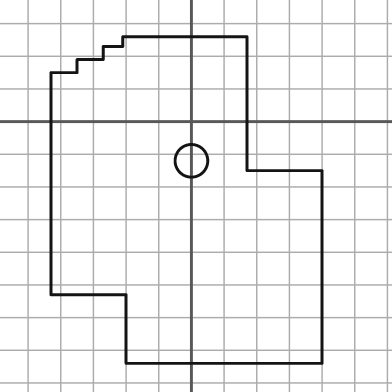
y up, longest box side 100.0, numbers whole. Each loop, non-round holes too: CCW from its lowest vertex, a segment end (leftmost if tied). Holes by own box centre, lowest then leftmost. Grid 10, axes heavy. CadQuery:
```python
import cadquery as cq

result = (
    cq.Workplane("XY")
    .moveTo(-20.0, -74.0)
    .lineTo(40.0, -74.0)
    .lineTo(40.0, -15.0)
    .lineTo(17.0, -15.0)
    .lineTo(17.0, 26.0)
    .lineTo(-21.0, 26.0)
    .lineTo(-21.0, 23.0)
    .lineTo(-27.0, 23.0)
    .lineTo(-27.0, 19.0)
    .lineTo(-35.0, 19.0)
    .lineTo(-35.0, 15.0)
    .lineTo(-43.0, 15.0)
    .lineTo(-43.0, -53.0)
    .lineTo(-20.0, -53.0)
    .close()
    .moveTo(0.0, -12.0)
    .circle(5.0)
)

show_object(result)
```